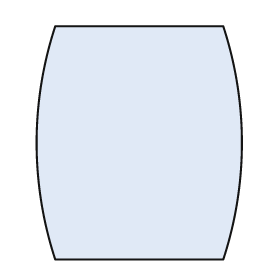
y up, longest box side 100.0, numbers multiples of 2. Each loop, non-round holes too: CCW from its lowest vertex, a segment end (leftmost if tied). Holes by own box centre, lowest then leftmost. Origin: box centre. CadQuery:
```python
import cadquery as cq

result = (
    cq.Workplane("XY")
    .moveTo(-36.0, -50.0)
    .lineTo(36.0, -50.0)
    .threePointArc((44.0, 0.0), (36.0, 50.0))
    .lineTo(-36.0, 50.0)
    .threePointArc((-44.0, 0.0), (-36.0, -50.0))
    .close()
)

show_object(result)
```